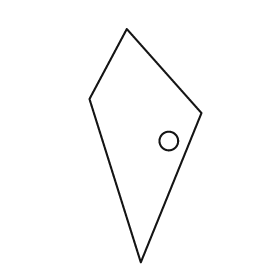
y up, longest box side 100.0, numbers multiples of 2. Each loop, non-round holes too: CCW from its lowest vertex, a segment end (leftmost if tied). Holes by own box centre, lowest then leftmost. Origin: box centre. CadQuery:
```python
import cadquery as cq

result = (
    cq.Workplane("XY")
    .moveTo(-2.0, -50.0)
    .lineTo(24.0, 14.0)
    .lineTo(-8.0, 50.0)
    .lineTo(-24.0, 20.0)
    .close()
    .moveTo(10.0, 2.0)
    .circle(4.0)
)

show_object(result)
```